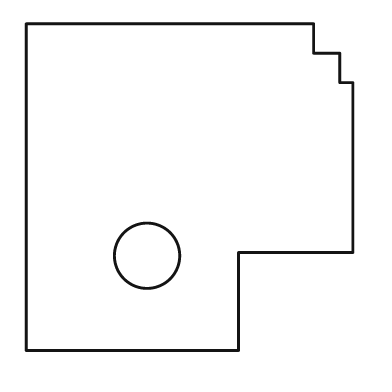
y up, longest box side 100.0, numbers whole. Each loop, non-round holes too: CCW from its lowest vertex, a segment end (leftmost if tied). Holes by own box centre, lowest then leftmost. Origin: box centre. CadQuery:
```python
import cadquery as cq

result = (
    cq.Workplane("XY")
    .moveTo(-50.0, -50.0)
    .lineTo(15.0, -50.0)
    .lineTo(15.0, -20.0)
    .lineTo(50.0, -20.0)
    .lineTo(50.0, 32.0)
    .lineTo(46.0, 32.0)
    .lineTo(46.0, 41.0)
    .lineTo(38.0, 41.0)
    .lineTo(38.0, 50.0)
    .lineTo(-50.0, 50.0)
    .close()
    .moveTo(-13.0, -21.0)
    .circle(10.0)
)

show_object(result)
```